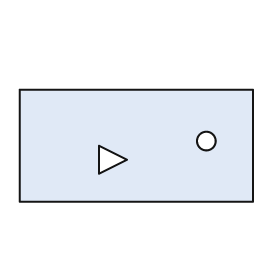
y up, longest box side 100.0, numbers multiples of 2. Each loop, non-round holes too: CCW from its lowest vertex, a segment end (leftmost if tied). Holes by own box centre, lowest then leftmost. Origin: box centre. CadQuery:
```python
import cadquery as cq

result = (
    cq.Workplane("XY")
    .moveTo(-50.0, -24.0)
    .lineTo(50.0, -24.0)
    .lineTo(50.0, 24.0)
    .lineTo(-50.0, 24.0)
    .close()
    .moveTo(-16.0, -12.0)
    .lineTo(-4.0, -6.0)
    .lineTo(-16.0, 0.0)
    .close()
    .moveTo(30.0, 2.0)
    .circle(4.0)
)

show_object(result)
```